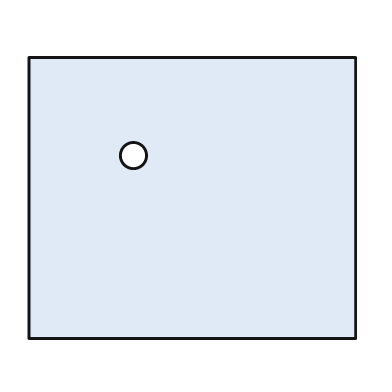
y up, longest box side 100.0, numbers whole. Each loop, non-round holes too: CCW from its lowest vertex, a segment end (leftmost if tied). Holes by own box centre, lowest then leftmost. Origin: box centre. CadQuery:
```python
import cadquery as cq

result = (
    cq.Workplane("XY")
    .moveTo(-50.0, -43.0)
    .lineTo(50.0, -43.0)
    .lineTo(50.0, 43.0)
    .lineTo(-50.0, 43.0)
    .close()
    .moveTo(-18.0, 13.0)
    .circle(4.0)
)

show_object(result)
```